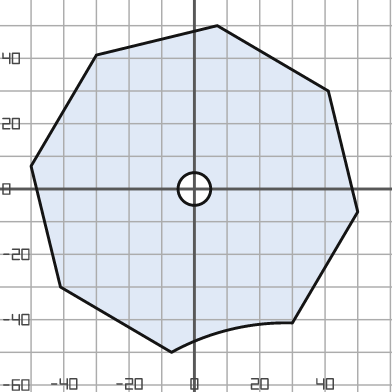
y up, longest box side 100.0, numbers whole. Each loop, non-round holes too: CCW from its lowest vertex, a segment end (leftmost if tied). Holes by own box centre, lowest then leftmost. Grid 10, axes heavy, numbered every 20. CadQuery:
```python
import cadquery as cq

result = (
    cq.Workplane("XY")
    .moveTo(-7.0, -50.0)
    .threePointArc((11.0, -43.0), (30.0, -41.0))
    .lineTo(50.0, -7.0)
    .lineTo(41.0, 30.0)
    .lineTo(7.0, 50.0)
    .lineTo(-30.0, 41.0)
    .lineTo(-50.0, 7.0)
    .lineTo(-41.0, -30.0)
    .close()
    .moveTo(0.0, 0.0)
    .circle(5.0)
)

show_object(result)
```